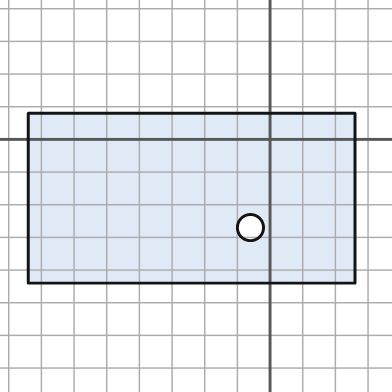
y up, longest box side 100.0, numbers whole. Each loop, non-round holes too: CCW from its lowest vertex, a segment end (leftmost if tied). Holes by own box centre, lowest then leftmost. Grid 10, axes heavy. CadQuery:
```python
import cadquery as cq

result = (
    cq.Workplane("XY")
    .moveTo(-74.0, -44.0)
    .lineTo(26.0, -44.0)
    .lineTo(26.0, 8.0)
    .lineTo(-74.0, 8.0)
    .close()
    .moveTo(-6.0, -27.0)
    .circle(4.0)
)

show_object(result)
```